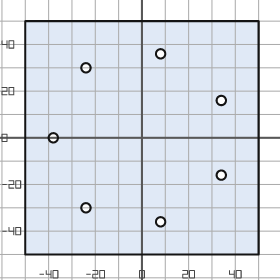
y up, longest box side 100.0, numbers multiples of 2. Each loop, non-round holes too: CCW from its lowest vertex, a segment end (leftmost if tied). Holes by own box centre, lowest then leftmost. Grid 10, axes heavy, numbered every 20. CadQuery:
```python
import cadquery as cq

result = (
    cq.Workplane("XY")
    .moveTo(-50.0, -50.0)
    .lineTo(50.0, -50.0)
    .lineTo(50.0, 50.0)
    .lineTo(-50.0, 50.0)
    .close()
    .moveTo(8.0, -36.0)
    .circle(2.0)
    .moveTo(-24.0, -30.0)
    .circle(2.0)
    .moveTo(34.0, -16.0)
    .circle(2.0)
    .moveTo(-38.0, 0.0)
    .circle(2.0)
    .moveTo(34.0, 16.0)
    .circle(2.0)
    .moveTo(-24.0, 30.0)
    .circle(2.0)
    .moveTo(8.0, 36.0)
    .circle(2.0)
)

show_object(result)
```